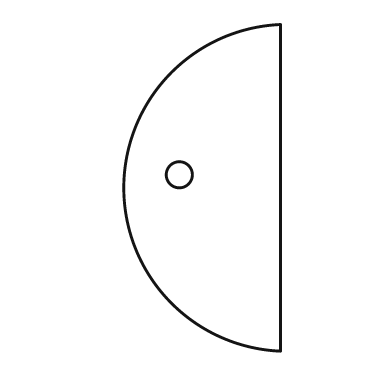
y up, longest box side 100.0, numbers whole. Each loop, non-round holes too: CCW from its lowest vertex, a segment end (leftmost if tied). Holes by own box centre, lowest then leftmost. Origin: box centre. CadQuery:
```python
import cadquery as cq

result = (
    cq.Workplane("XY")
    .moveTo(24.0, -50.0)
    .lineTo(24.0, 50.0)
    .threePointArc((-24.0, 0.0), (24.0, -50.0))
    .close()
    .moveTo(-7.0, 4.0)
    .circle(4.0)
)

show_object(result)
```